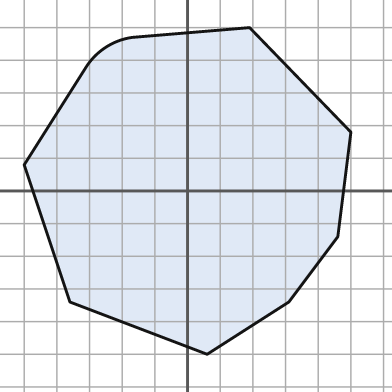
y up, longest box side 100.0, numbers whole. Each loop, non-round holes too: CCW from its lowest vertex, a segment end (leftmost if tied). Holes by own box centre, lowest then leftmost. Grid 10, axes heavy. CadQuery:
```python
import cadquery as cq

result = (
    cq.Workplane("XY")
    .moveTo(6.0, -50.0)
    .lineTo(31.0, -34.0)
    .lineTo(46.0, -14.0)
    .lineTo(50.0, 18.0)
    .lineTo(19.0, 50.0)
    .lineTo(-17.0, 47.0)
    .threePointArc((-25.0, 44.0), (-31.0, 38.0))
    .lineTo(-50.0, 8.0)
    .lineTo(-36.0, -34.0)
    .close()
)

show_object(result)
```